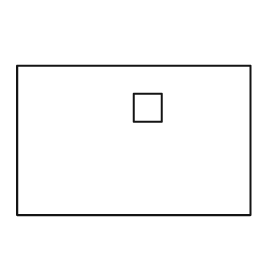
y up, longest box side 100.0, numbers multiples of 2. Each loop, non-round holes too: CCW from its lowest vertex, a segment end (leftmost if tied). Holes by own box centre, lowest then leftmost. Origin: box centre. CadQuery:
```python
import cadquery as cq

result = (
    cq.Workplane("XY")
    .moveTo(-50.0, -32.0)
    .lineTo(50.0, -32.0)
    .lineTo(50.0, 32.0)
    .lineTo(-50.0, 32.0)
    .close()
    .moveTo(0.0, 8.0)
    .lineTo(12.0, 8.0)
    .lineTo(12.0, 20.0)
    .lineTo(0.0, 20.0)
    .close()
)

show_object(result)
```